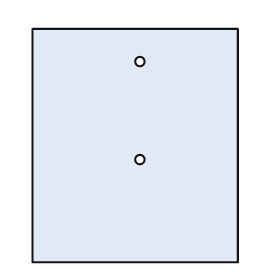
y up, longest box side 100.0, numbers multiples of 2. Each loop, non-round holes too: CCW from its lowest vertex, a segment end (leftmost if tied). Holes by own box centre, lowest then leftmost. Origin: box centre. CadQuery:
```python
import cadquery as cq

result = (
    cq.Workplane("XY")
    .moveTo(-44.0, -50.0)
    .lineTo(44.0, -50.0)
    .lineTo(44.0, 50.0)
    .lineTo(-44.0, 50.0)
    .close()
    .moveTo(2.0, -6.0)
    .circle(2.0)
    .moveTo(2.0, 36.0)
    .circle(2.0)
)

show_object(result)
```